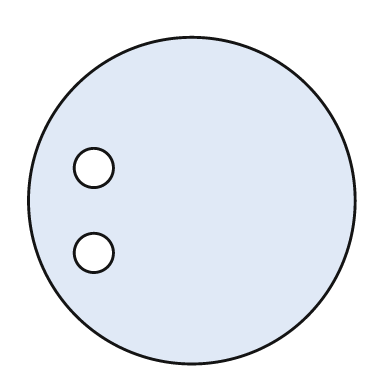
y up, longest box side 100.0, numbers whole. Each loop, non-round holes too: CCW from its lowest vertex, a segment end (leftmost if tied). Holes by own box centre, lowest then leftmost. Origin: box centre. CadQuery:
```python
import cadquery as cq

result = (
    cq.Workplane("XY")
    .moveTo(0.0, 0.0)
    .circle(50.0)
    .moveTo(-30.0, -16.0)
    .circle(6.0)
    .moveTo(-30.0, 10.0)
    .circle(6.0)
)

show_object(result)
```